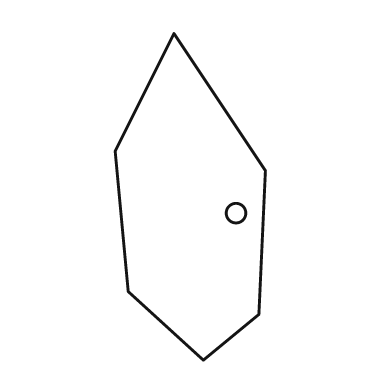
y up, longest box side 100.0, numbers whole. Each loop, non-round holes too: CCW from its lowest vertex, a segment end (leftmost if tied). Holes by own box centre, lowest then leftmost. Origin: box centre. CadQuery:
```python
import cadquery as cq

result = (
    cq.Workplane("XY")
    .moveTo(4.0, -50.0)
    .lineTo(21.0, -36.0)
    .lineTo(23.0, 8.0)
    .lineTo(-5.0, 50.0)
    .lineTo(-23.0, 14.0)
    .lineTo(-19.0, -29.0)
    .close()
    .moveTo(14.0, -5.0)
    .circle(3.0)
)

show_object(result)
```